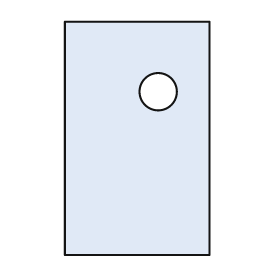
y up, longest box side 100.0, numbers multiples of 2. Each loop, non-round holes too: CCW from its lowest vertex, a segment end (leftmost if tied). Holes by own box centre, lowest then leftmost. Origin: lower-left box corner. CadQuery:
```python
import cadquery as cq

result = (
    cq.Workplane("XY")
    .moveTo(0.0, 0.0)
    .lineTo(62.0, 0.0)
    .lineTo(62.0, 100.0)
    .lineTo(0.0, 100.0)
    .close()
    .moveTo(40.0, 70.0)
    .circle(8.0)
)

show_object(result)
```